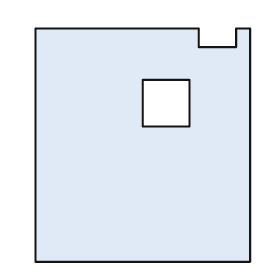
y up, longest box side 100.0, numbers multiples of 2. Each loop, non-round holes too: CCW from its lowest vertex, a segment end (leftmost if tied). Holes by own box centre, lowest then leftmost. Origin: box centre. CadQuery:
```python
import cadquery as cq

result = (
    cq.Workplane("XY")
    .moveTo(-46.0, -50.0)
    .lineTo(46.0, -50.0)
    .lineTo(46.0, 50.0)
    .lineTo(40.0, 50.0)
    .lineTo(40.0, 42.0)
    .lineTo(24.0, 42.0)
    .lineTo(24.0, 50.0)
    .lineTo(-46.0, 50.0)
    .close()
    .moveTo(0.0, 8.0)
    .lineTo(20.0, 8.0)
    .lineTo(20.0, 28.0)
    .lineTo(0.0, 28.0)
    .close()
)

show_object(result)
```